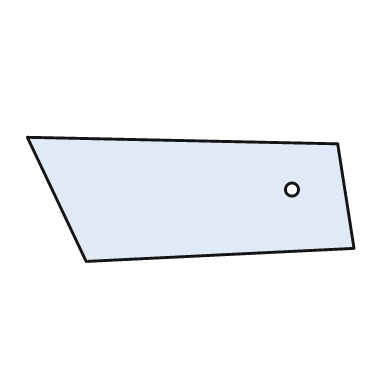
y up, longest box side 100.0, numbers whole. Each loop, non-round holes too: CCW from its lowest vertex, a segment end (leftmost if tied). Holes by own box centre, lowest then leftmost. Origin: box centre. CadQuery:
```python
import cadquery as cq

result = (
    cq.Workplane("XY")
    .moveTo(-32.0, -19.0)
    .lineTo(50.0, -15.0)
    .lineTo(45.0, 17.0)
    .lineTo(-50.0, 19.0)
    .close()
    .moveTo(31.0, 3.0)
    .circle(2.0)
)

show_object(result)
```